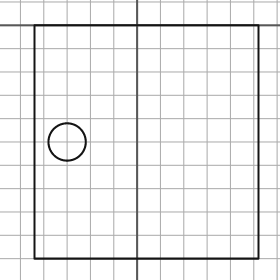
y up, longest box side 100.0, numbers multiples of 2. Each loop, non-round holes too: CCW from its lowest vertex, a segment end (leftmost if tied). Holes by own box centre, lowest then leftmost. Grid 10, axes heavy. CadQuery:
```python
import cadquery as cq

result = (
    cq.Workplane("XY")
    .moveTo(-44.0, -100.0)
    .lineTo(52.0, -100.0)
    .lineTo(52.0, 0.0)
    .lineTo(-44.0, 0.0)
    .close()
    .moveTo(-30.0, -50.0)
    .circle(8.0)
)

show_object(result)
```